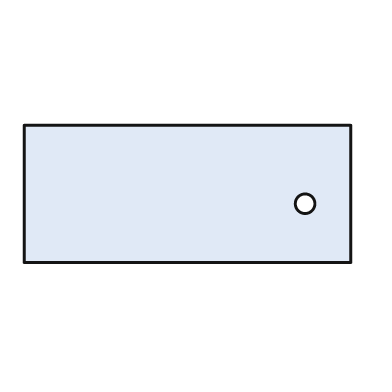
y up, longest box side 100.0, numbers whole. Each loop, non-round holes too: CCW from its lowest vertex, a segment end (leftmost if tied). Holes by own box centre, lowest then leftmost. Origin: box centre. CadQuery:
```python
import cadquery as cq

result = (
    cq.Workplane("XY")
    .moveTo(-50.0, -21.0)
    .lineTo(50.0, -21.0)
    .lineTo(50.0, 21.0)
    .lineTo(-50.0, 21.0)
    .close()
    .moveTo(36.0, -3.0)
    .circle(3.0)
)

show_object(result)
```